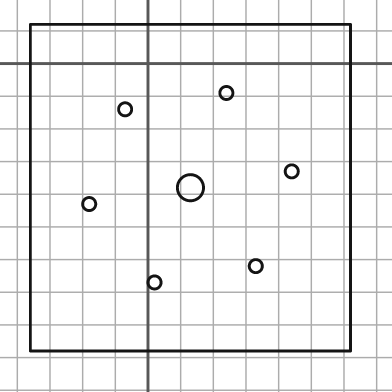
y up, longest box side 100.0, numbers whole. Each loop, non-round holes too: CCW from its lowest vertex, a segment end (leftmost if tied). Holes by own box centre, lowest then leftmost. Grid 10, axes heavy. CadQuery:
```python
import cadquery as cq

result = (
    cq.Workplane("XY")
    .moveTo(-36.0, -88.0)
    .lineTo(62.0, -88.0)
    .lineTo(62.0, 12.0)
    .lineTo(-36.0, 12.0)
    .close()
    .moveTo(2.0, -67.0)
    .circle(2.0)
    .moveTo(33.0, -62.0)
    .circle(2.0)
    .moveTo(-18.0, -43.0)
    .circle(2.0)
    .moveTo(13.0, -38.0)
    .circle(4.0)
    .moveTo(44.0, -33.0)
    .circle(2.0)
    .moveTo(-7.0, -14.0)
    .circle(2.0)
    .moveTo(24.0, -9.0)
    .circle(2.0)
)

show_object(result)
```